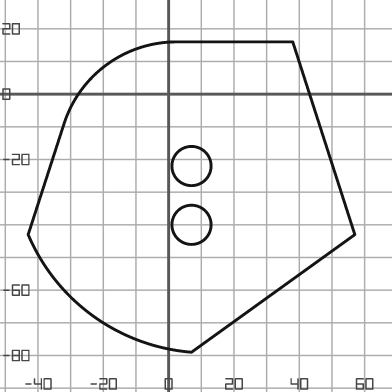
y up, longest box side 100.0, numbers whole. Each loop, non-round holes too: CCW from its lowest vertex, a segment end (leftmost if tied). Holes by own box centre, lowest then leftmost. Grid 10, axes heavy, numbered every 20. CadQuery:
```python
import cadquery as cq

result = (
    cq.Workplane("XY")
    .moveTo(7.0, -79.0)
    .lineTo(57.0, -43.0)
    .lineTo(38.0, 16.0)
    .lineTo(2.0, 16.0)
    .threePointArc((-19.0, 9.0), (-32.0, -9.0))
    .lineTo(-43.0, -43.0)
    .threePointArc((-23.0, -68.0), (7.0, -79.0))
    .close()
    .moveTo(7.0, -40.0)
    .circle(6.0)
    .moveTo(7.0, -22.0)
    .circle(6.0)
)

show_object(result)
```